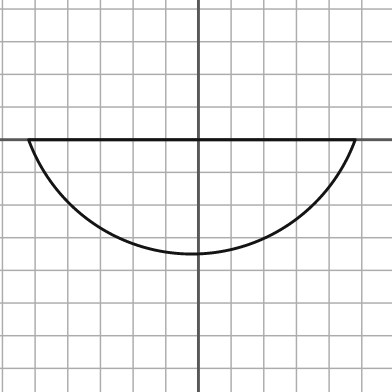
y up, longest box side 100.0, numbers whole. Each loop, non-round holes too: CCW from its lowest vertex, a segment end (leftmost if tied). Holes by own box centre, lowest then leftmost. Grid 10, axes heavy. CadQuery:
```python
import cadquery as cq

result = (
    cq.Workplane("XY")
    .moveTo(-52.0, 0.0)
    .threePointArc((-2.0, -35.0), (48.0, 0.0))
    .close()
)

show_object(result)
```